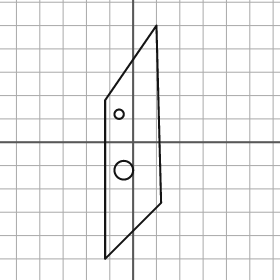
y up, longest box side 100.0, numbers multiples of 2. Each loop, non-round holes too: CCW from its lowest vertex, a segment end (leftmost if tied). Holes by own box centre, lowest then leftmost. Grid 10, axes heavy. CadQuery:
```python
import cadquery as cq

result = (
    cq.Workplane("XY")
    .moveTo(-12.0, -50.0)
    .lineTo(12.0, -26.0)
    .lineTo(10.0, 50.0)
    .lineTo(-12.0, 18.0)
    .close()
    .moveTo(-4.0, -12.0)
    .circle(4.0)
    .moveTo(-6.0, 12.0)
    .circle(2.0)
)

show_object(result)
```